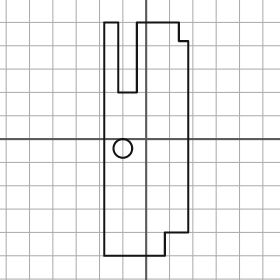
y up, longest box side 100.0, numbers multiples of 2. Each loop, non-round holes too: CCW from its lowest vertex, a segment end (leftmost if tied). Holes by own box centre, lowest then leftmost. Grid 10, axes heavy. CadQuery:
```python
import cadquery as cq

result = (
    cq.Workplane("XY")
    .moveTo(-18.0, -50.0)
    .lineTo(8.0, -50.0)
    .lineTo(8.0, -40.0)
    .lineTo(18.0, -40.0)
    .lineTo(18.0, 42.0)
    .lineTo(14.0, 42.0)
    .lineTo(14.0, 50.0)
    .lineTo(-4.0, 50.0)
    .lineTo(-4.0, 20.0)
    .lineTo(-12.0, 20.0)
    .lineTo(-12.0, 50.0)
    .lineTo(-18.0, 50.0)
    .close()
    .moveTo(-10.0, -4.0)
    .circle(4.0)
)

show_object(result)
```